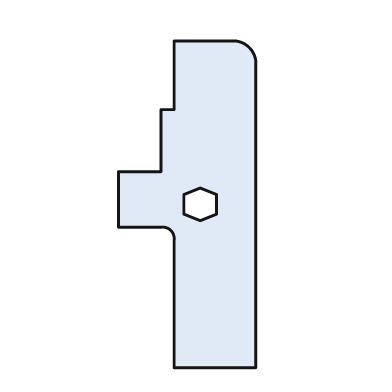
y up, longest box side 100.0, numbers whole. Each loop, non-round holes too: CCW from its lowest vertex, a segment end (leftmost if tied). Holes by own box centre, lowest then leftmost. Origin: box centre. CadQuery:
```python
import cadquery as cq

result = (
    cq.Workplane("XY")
    .moveTo(-4.0, -50.0)
    .lineTo(21.0, -50.0)
    .lineTo(21.0, 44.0)
    .threePointArc((19.0, 48.0), (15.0, 50.0))
    .lineTo(-4.0, 50.0)
    .lineTo(-4.0, 29.0)
    .lineTo(-8.0, 29.0)
    .lineTo(-8.0, 10.0)
    .lineTo(-21.0, 10.0)
    .lineTo(-21.0, -7.0)
    .lineTo(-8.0, -7.0)
    .threePointArc((-5.0, -8.0), (-4.0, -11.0))
    .close()
    .moveTo(4.0, -5.0)
    .lineTo(9.0, -3.0)
    .lineTo(9.0, 3.0)
    .lineTo(4.0, 5.0)
    .lineTo(-1.0, 3.0)
    .lineTo(-1.0, -3.0)
    .close()
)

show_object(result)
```